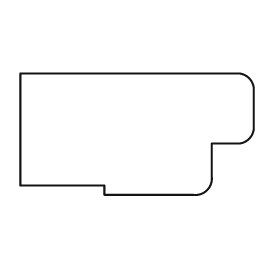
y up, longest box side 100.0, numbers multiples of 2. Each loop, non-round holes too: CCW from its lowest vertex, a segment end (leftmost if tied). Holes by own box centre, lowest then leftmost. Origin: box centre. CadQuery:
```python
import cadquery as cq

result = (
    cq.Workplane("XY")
    .moveTo(-14.0, -26.0)
    .lineTo(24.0, -26.0)
    .threePointArc((30.0, -24.0), (32.0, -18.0))
    .lineTo(32.0, -4.0)
    .lineTo(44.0, -4.0)
    .threePointArc((48.0, -2.0), (50.0, 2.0))
    .lineTo(50.0, 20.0)
    .threePointArc((48.0, 24.0), (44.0, 26.0))
    .lineTo(-50.0, 26.0)
    .lineTo(-50.0, -22.0)
    .lineTo(-14.0, -22.0)
    .close()
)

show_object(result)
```